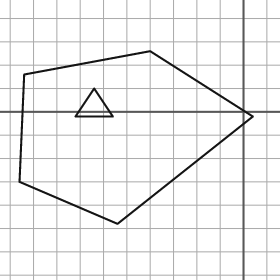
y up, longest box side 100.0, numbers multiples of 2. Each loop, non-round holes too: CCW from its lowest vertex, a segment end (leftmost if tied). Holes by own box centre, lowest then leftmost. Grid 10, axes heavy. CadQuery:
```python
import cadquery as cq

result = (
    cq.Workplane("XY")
    .moveTo(-54.0, -48.0)
    .lineTo(4.0, -2.0)
    .lineTo(-40.0, 26.0)
    .lineTo(-94.0, 16.0)
    .lineTo(-96.0, -30.0)
    .close()
    .moveTo(-72.0, -2.0)
    .lineTo(-56.0, -2.0)
    .lineTo(-64.0, 10.0)
    .close()
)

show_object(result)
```